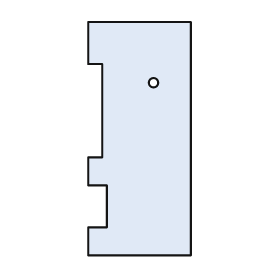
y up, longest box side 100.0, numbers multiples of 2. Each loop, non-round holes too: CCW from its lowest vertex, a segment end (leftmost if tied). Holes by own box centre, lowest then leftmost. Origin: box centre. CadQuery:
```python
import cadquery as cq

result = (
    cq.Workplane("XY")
    .moveTo(-22.0, -50.0)
    .lineTo(22.0, -50.0)
    .lineTo(22.0, 50.0)
    .lineTo(-22.0, 50.0)
    .lineTo(-22.0, 32.0)
    .lineTo(-16.0, 32.0)
    .lineTo(-16.0, -8.0)
    .lineTo(-22.0, -8.0)
    .lineTo(-22.0, -20.0)
    .lineTo(-14.0, -20.0)
    .lineTo(-14.0, -38.0)
    .lineTo(-22.0, -38.0)
    .close()
    .moveTo(6.0, 24.0)
    .circle(2.0)
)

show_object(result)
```